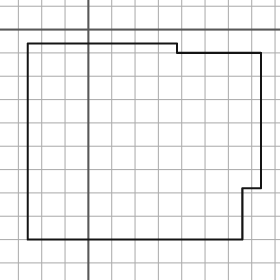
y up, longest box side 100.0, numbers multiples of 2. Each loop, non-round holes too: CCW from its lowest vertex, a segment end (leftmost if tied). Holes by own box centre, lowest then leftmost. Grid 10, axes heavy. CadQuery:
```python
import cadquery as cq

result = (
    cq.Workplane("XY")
    .moveTo(-26.0, -90.0)
    .lineTo(66.0, -90.0)
    .lineTo(66.0, -68.0)
    .lineTo(74.0, -68.0)
    .lineTo(74.0, -10.0)
    .lineTo(38.0, -10.0)
    .lineTo(38.0, -6.0)
    .lineTo(-26.0, -6.0)
    .close()
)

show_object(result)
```